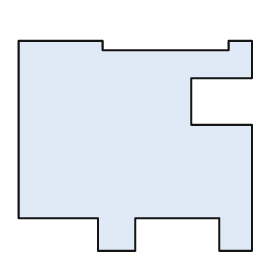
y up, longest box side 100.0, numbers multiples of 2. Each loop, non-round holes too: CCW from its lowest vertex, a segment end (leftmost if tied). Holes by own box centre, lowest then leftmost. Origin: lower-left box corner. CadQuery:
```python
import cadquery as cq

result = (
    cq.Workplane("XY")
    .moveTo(34.0, 0.0)
    .lineTo(50.0, 0.0)
    .lineTo(50.0, 14.0)
    .lineTo(86.0, 14.0)
    .lineTo(86.0, 0.0)
    .lineTo(100.0, 0.0)
    .lineTo(100.0, 54.0)
    .lineTo(74.0, 54.0)
    .lineTo(74.0, 74.0)
    .lineTo(100.0, 74.0)
    .lineTo(100.0, 90.0)
    .lineTo(90.0, 90.0)
    .lineTo(90.0, 86.0)
    .lineTo(36.0, 86.0)
    .lineTo(36.0, 90.0)
    .lineTo(0.0, 90.0)
    .lineTo(0.0, 14.0)
    .lineTo(34.0, 14.0)
    .close()
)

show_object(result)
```